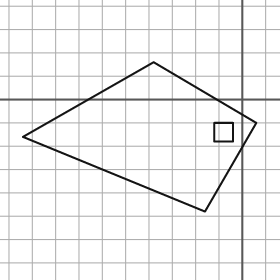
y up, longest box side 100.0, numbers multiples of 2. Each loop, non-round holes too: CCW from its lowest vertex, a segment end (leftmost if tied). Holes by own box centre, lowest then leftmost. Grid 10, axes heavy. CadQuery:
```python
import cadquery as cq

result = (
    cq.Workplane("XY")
    .moveTo(-16.0, -48.0)
    .lineTo(6.0, -10.0)
    .lineTo(-38.0, 16.0)
    .lineTo(-94.0, -16.0)
    .close()
    .moveTo(-12.0, -18.0)
    .lineTo(-4.0, -18.0)
    .lineTo(-4.0, -10.0)
    .lineTo(-12.0, -10.0)
    .close()
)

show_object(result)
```